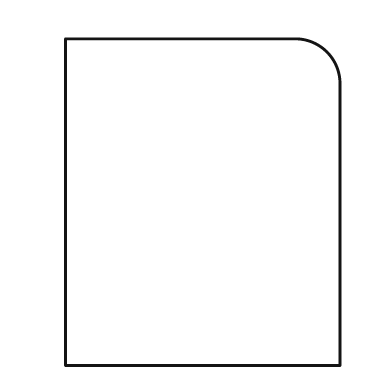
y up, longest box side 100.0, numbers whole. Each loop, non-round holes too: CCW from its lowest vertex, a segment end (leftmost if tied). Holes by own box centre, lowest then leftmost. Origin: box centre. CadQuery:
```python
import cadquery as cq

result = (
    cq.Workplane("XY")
    .moveTo(-42.0, -50.0)
    .lineTo(42.0, -50.0)
    .lineTo(42.0, 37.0)
    .threePointArc((38.0, 46.0), (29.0, 50.0))
    .lineTo(-42.0, 50.0)
    .close()
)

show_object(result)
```